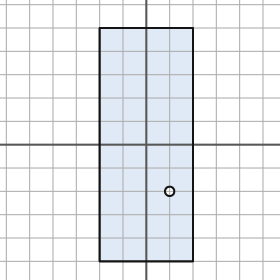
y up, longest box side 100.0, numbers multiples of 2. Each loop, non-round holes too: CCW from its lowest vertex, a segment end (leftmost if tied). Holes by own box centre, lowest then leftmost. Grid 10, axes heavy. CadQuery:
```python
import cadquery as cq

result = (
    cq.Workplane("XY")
    .moveTo(-20.0, -50.0)
    .lineTo(20.0, -50.0)
    .lineTo(20.0, 50.0)
    .lineTo(-20.0, 50.0)
    .close()
    .moveTo(10.0, -20.0)
    .circle(2.0)
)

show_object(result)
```